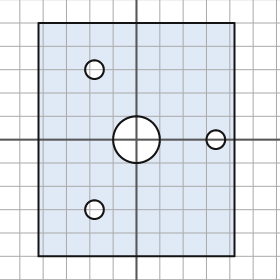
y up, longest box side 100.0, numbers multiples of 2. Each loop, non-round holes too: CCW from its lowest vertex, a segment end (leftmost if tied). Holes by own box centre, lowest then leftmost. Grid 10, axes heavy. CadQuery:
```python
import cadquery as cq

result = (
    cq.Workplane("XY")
    .moveTo(-42.0, -50.0)
    .lineTo(42.0, -50.0)
    .lineTo(42.0, 50.0)
    .lineTo(-42.0, 50.0)
    .close()
    .moveTo(-18.0, -30.0)
    .circle(4.0)
    .moveTo(0.0, 0.0)
    .circle(10.0)
    .moveTo(34.0, 0.0)
    .circle(4.0)
    .moveTo(-18.0, 30.0)
    .circle(4.0)
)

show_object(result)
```